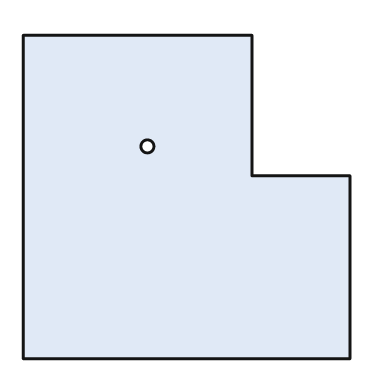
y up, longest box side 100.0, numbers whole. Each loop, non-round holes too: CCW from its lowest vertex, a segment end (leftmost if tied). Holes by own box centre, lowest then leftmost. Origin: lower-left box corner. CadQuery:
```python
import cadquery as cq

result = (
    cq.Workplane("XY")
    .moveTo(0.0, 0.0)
    .lineTo(100.0, 0.0)
    .lineTo(100.0, 56.0)
    .lineTo(70.0, 56.0)
    .lineTo(70.0, 99.0)
    .lineTo(0.0, 99.0)
    .close()
    .moveTo(38.0, 65.0)
    .circle(2.0)
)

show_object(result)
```